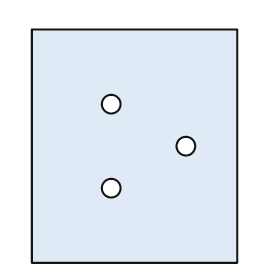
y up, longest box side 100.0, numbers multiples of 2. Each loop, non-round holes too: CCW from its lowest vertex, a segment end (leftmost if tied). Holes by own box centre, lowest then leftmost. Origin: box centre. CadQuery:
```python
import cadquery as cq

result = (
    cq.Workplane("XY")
    .moveTo(-44.0, -50.0)
    .lineTo(44.0, -50.0)
    .lineTo(44.0, 50.0)
    .lineTo(-44.0, 50.0)
    .close()
    .moveTo(-10.0, -18.0)
    .circle(4.0)
    .moveTo(22.0, 0.0)
    .circle(4.0)
    .moveTo(-10.0, 18.0)
    .circle(4.0)
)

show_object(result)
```